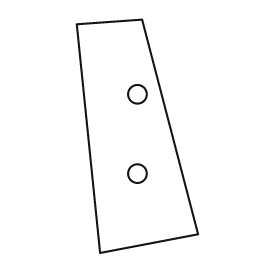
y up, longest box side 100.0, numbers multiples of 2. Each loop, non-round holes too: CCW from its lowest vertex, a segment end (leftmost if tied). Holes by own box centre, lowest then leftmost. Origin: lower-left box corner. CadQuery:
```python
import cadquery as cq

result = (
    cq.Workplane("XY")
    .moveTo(10.0, 0.0)
    .lineTo(52.0, 8.0)
    .lineTo(28.0, 100.0)
    .lineTo(0.0, 98.0)
    .close()
    .moveTo(26.0, 34.0)
    .circle(4.0)
    .moveTo(26.0, 68.0)
    .circle(4.0)
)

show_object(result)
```